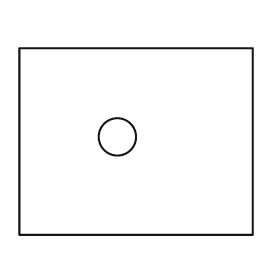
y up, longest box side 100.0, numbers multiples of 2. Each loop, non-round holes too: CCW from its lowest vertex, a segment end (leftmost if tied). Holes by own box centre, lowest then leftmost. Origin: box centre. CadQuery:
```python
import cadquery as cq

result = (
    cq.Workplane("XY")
    .moveTo(-50.0, -40.0)
    .lineTo(50.0, -40.0)
    .lineTo(50.0, 40.0)
    .lineTo(-50.0, 40.0)
    .close()
    .moveTo(-8.0, 2.0)
    .circle(8.0)
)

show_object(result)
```